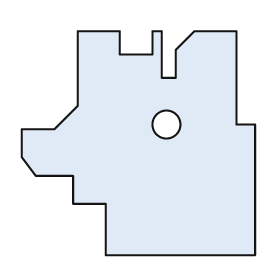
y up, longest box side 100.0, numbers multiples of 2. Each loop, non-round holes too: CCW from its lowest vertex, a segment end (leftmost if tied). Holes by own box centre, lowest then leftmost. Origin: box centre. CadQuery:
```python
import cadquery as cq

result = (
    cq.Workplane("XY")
    .moveTo(-14.0, -48.0)
    .lineTo(50.0, -48.0)
    .lineTo(50.0, 8.0)
    .lineTo(42.0, 8.0)
    .lineTo(42.0, 48.0)
    .lineTo(24.0, 48.0)
    .lineTo(16.0, 40.0)
    .lineTo(16.0, 28.0)
    .lineTo(10.0, 28.0)
    .lineTo(10.0, 48.0)
    .lineTo(6.0, 48.0)
    .lineTo(6.0, 38.0)
    .lineTo(-8.0, 38.0)
    .lineTo(-8.0, 48.0)
    .lineTo(-26.0, 48.0)
    .lineTo(-26.0, 16.0)
    .lineTo(-36.0, 6.0)
    .lineTo(-50.0, 6.0)
    .lineTo(-50.0, -6.0)
    .lineTo(-44.0, -14.0)
    .lineTo(-28.0, -14.0)
    .lineTo(-28.0, -26.0)
    .lineTo(-14.0, -26.0)
    .close()
    .moveTo(12.0, 8.0)
    .circle(6.0)
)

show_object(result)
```